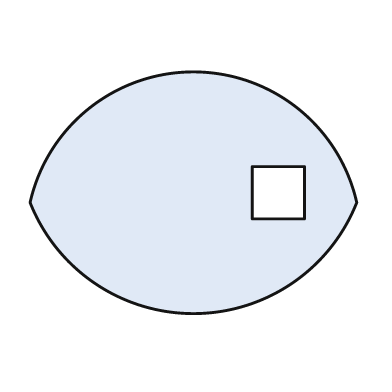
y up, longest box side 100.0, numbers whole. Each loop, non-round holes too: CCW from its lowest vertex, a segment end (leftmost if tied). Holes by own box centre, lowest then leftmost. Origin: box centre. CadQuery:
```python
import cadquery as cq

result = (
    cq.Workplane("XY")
    .moveTo(-50.0, -3.0)
    .threePointArc((0.0, -37.0), (50.0, -3.0))
    .threePointArc((0.0, 37.0), (-50.0, -3.0))
    .close()
    .moveTo(18.0, -8.0)
    .lineTo(34.0, -8.0)
    .lineTo(34.0, 8.0)
    .lineTo(18.0, 8.0)
    .close()
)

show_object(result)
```